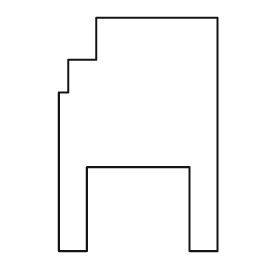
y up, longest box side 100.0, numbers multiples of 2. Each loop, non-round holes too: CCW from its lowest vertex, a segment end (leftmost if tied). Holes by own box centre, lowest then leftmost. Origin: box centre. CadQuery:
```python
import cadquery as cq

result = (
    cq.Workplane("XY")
    .moveTo(-34.0, -50.0)
    .lineTo(-22.0, -50.0)
    .lineTo(-22.0, -14.0)
    .lineTo(22.0, -14.0)
    .lineTo(22.0, -50.0)
    .lineTo(34.0, -50.0)
    .lineTo(34.0, 50.0)
    .lineTo(-18.0, 50.0)
    .lineTo(-18.0, 32.0)
    .lineTo(-30.0, 32.0)
    .lineTo(-30.0, 18.0)
    .lineTo(-34.0, 18.0)
    .close()
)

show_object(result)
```